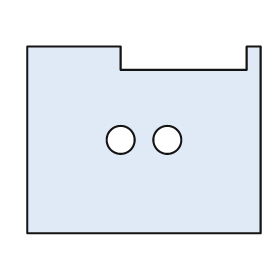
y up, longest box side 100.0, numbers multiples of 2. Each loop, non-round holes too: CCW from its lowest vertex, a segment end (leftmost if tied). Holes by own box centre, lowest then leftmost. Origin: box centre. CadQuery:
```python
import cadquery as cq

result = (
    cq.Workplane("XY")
    .moveTo(-50.0, -40.0)
    .lineTo(50.0, -40.0)
    .lineTo(50.0, 40.0)
    .lineTo(44.0, 40.0)
    .lineTo(44.0, 30.0)
    .lineTo(-10.0, 30.0)
    .lineTo(-10.0, 40.0)
    .lineTo(-50.0, 40.0)
    .close()
    .moveTo(-10.0, 0.0)
    .circle(6.0)
    .moveTo(10.0, 0.0)
    .circle(6.0)
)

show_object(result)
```